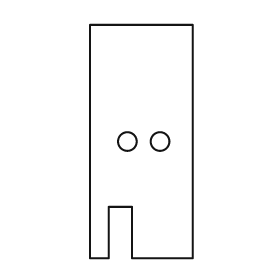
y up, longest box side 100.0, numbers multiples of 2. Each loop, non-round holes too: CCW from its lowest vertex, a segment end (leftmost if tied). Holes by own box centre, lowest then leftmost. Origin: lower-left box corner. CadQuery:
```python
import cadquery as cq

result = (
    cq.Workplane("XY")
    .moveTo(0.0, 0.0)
    .lineTo(8.0, 0.0)
    .lineTo(8.0, 22.0)
    .lineTo(18.0, 22.0)
    .lineTo(18.0, 0.0)
    .lineTo(44.0, 0.0)
    .lineTo(44.0, 100.0)
    .lineTo(0.0, 100.0)
    .close()
    .moveTo(16.0, 50.0)
    .circle(4.0)
    .moveTo(30.0, 50.0)
    .circle(4.0)
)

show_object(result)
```